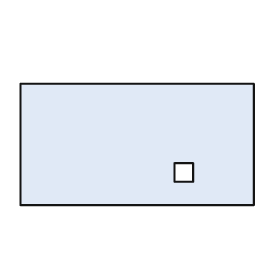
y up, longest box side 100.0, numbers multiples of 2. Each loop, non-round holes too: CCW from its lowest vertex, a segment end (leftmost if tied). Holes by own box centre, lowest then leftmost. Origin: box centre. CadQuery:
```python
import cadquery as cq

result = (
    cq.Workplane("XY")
    .moveTo(-50.0, -26.0)
    .lineTo(50.0, -26.0)
    .lineTo(50.0, 26.0)
    .lineTo(-50.0, 26.0)
    .close()
    .moveTo(16.0, -16.0)
    .lineTo(24.0, -16.0)
    .lineTo(24.0, -8.0)
    .lineTo(16.0, -8.0)
    .close()
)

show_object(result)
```